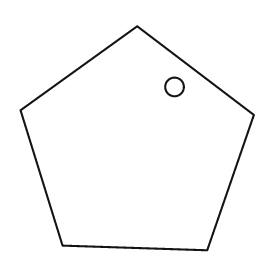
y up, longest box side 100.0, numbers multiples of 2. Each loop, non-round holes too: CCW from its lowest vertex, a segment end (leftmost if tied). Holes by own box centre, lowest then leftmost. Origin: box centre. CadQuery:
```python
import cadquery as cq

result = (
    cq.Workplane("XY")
    .moveTo(30.0, -48.0)
    .lineTo(50.0, 10.0)
    .lineTo(0.0, 48.0)
    .lineTo(-50.0, 12.0)
    .lineTo(-32.0, -46.0)
    .close()
    .moveTo(16.0, 22.0)
    .circle(4.0)
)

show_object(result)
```